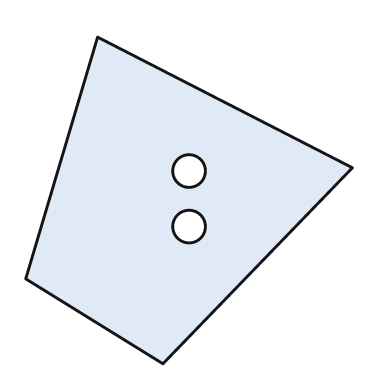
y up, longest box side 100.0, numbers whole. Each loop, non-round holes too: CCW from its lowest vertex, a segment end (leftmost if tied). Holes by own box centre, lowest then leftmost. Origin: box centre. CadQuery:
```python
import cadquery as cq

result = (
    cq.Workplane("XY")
    .moveTo(-8.0, -50.0)
    .lineTo(50.0, 10.0)
    .lineTo(-28.0, 50.0)
    .lineTo(-50.0, -24.0)
    .close()
    .moveTo(0.0, -8.0)
    .circle(5.0)
    .moveTo(0.0, 9.0)
    .circle(5.0)
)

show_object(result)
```